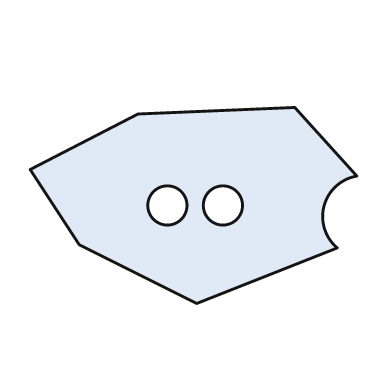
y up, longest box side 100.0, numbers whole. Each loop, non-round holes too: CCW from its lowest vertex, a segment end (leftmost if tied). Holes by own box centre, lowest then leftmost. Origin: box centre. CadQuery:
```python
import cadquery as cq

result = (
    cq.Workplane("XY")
    .moveTo(1.0, -30.0)
    .lineTo(44.0, -13.0)
    .threePointArc((40.0, 0.0), (50.0, 9.0))
    .lineTo(31.0, 30.0)
    .lineTo(-17.0, 28.0)
    .lineTo(-50.0, 11.0)
    .lineTo(-35.0, -12.0)
    .close()
    .moveTo(-8.0, 0.0)
    .circle(6.0)
    .moveTo(9.0, 0.0)
    .circle(6.0)
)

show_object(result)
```